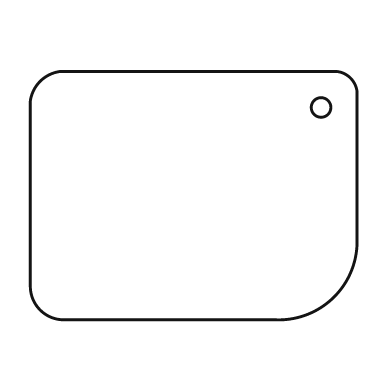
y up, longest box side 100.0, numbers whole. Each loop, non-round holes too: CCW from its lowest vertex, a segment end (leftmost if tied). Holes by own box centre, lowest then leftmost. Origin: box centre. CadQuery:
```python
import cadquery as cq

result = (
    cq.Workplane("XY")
    .moveTo(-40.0, -38.0)
    .lineTo(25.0, -38.0)
    .threePointArc((43.0, -31.0), (50.0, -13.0))
    .lineTo(50.0, 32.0)
    .threePointArc((48.0, 36.0), (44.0, 38.0))
    .lineTo(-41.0, 38.0)
    .threePointArc((-47.0, 35.0), (-50.0, 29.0))
    .lineTo(-50.0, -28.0)
    .threePointArc((-47.0, -35.0), (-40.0, -38.0))
    .close()
    .moveTo(39.0, 27.0)
    .circle(3.0)
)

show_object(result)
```